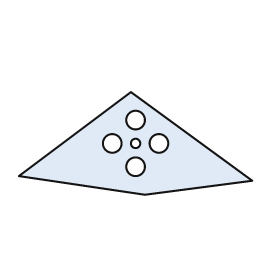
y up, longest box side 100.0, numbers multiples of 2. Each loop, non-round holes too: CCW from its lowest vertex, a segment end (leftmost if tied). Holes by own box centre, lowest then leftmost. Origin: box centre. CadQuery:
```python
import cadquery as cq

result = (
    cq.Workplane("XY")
    .moveTo(4.0, -22.0)
    .lineTo(50.0, -16.0)
    .lineTo(-2.0, 22.0)
    .lineTo(-50.0, -14.0)
    .close()
    .moveTo(0.0, -10.0)
    .circle(4.0)
    .moveTo(-10.0, 0.0)
    .circle(4.0)
    .moveTo(0.0, 0.0)
    .circle(2.0)
    .moveTo(10.0, 0.0)
    .circle(4.0)
    .moveTo(0.0, 10.0)
    .circle(4.0)
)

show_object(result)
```